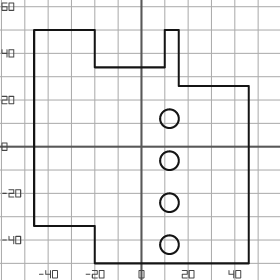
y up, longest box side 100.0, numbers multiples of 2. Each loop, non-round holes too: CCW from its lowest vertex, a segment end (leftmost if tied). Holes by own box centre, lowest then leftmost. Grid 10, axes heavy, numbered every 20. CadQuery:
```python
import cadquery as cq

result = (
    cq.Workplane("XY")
    .moveTo(-20.0, -50.0)
    .lineTo(46.0, -50.0)
    .lineTo(46.0, 26.0)
    .lineTo(16.0, 26.0)
    .lineTo(16.0, 50.0)
    .lineTo(10.0, 50.0)
    .lineTo(10.0, 34.0)
    .lineTo(-20.0, 34.0)
    .lineTo(-20.0, 50.0)
    .lineTo(-46.0, 50.0)
    .lineTo(-46.0, -34.0)
    .lineTo(-20.0, -34.0)
    .close()
    .moveTo(12.0, -42.0)
    .circle(4.0)
    .moveTo(12.0, -24.0)
    .circle(4.0)
    .moveTo(12.0, -6.0)
    .circle(4.0)
    .moveTo(12.0, 12.0)
    .circle(4.0)
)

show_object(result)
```